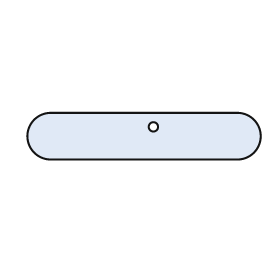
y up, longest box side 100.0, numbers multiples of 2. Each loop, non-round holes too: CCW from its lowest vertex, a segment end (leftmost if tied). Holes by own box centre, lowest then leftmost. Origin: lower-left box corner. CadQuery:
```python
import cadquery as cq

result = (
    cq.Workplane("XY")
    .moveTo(10.0, 0.0)
    .lineTo(90.0, 0.0)
    .threePointArc((100.0, 10.0), (90.0, 20.0))
    .lineTo(10.0, 20.0)
    .threePointArc((0.0, 10.0), (10.0, 0.0))
    .close()
    .moveTo(54.0, 14.0)
    .circle(2.0)
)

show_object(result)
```